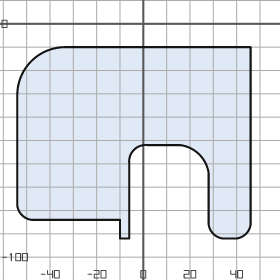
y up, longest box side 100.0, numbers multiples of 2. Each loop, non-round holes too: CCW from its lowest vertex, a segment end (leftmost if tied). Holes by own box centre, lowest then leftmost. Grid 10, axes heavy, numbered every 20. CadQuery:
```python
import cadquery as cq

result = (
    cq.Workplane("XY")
    .moveTo(-10.0, -92.0)
    .lineTo(-6.0, -92.0)
    .lineTo(-6.0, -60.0)
    .threePointArc((-4.0, -54.0), (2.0, -52.0))
    .lineTo(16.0, -52.0)
    .threePointArc((24.0, -56.0), (28.0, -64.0))
    .lineTo(28.0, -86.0)
    .threePointArc((30.0, -90.0), (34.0, -92.0))
    .lineTo(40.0, -92.0)
    .threePointArc((44.0, -90.0), (46.0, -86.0))
    .lineTo(46.0, -10.0)
    .lineTo(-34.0, -10.0)
    .threePointArc((-48.0, -16.0), (-54.0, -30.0))
    .lineTo(-54.0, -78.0)
    .threePointArc((-52.0, -82.0), (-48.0, -84.0))
    .lineTo(-10.0, -84.0)
    .close()
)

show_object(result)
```